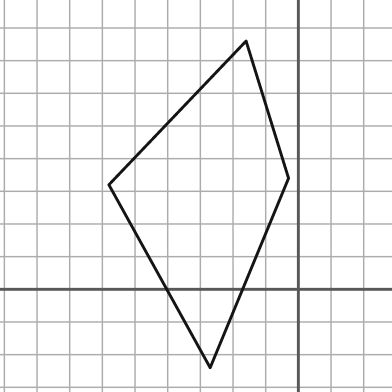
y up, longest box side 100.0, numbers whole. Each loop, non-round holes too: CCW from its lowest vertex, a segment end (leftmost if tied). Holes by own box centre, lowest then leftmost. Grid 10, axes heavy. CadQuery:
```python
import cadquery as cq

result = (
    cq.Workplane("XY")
    .moveTo(-27.0, -24.0)
    .lineTo(-3.0, 34.0)
    .lineTo(-16.0, 76.0)
    .lineTo(-58.0, 32.0)
    .close()
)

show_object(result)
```